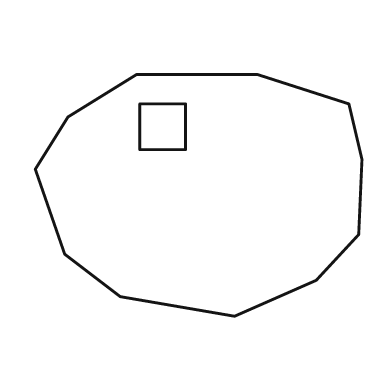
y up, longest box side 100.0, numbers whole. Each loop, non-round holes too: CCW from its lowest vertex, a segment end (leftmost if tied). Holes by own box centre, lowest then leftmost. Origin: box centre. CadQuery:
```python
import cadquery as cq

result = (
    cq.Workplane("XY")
    .moveTo(11.0, -37.0)
    .lineTo(36.0, -26.0)
    .lineTo(49.0, -12.0)
    .lineTo(50.0, 11.0)
    .lineTo(46.0, 28.0)
    .lineTo(18.0, 37.0)
    .lineTo(-19.0, 37.0)
    .lineTo(-40.0, 24.0)
    .lineTo(-50.0, 8.0)
    .lineTo(-41.0, -18.0)
    .lineTo(-24.0, -31.0)
    .close()
    .moveTo(-18.0, 14.0)
    .lineTo(-4.0, 14.0)
    .lineTo(-4.0, 28.0)
    .lineTo(-18.0, 28.0)
    .close()
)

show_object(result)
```